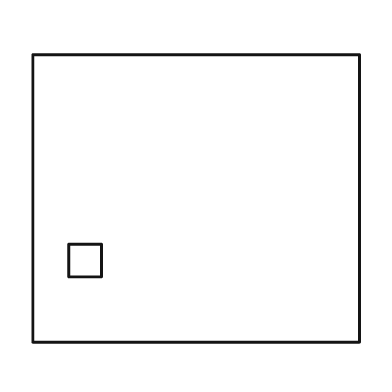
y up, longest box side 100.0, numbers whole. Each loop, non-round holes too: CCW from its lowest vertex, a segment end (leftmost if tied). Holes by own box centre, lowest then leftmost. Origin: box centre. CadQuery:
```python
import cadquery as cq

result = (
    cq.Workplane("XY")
    .moveTo(-50.0, -44.0)
    .lineTo(50.0, -44.0)
    .lineTo(50.0, 44.0)
    .lineTo(-50.0, 44.0)
    .close()
    .moveTo(-39.0, -24.0)
    .lineTo(-29.0, -24.0)
    .lineTo(-29.0, -14.0)
    .lineTo(-39.0, -14.0)
    .close()
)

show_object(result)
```